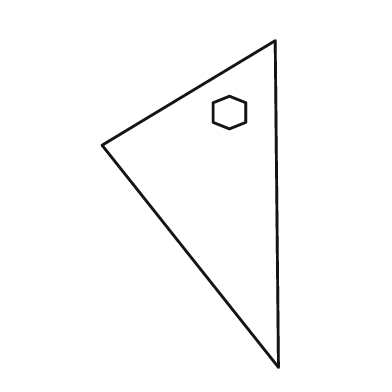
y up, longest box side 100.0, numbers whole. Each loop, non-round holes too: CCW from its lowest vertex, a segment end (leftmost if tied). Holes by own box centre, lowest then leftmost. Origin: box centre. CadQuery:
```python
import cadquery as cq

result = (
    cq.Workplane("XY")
    .moveTo(27.0, -50.0)
    .lineTo(26.0, 50.0)
    .lineTo(-27.0, 18.0)
    .close()
    .moveTo(12.0, 23.0)
    .lineTo(17.0, 25.0)
    .lineTo(17.0, 31.0)
    .lineTo(12.0, 33.0)
    .lineTo(7.0, 31.0)
    .lineTo(7.0, 25.0)
    .close()
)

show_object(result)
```